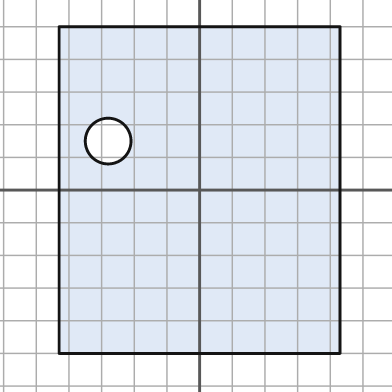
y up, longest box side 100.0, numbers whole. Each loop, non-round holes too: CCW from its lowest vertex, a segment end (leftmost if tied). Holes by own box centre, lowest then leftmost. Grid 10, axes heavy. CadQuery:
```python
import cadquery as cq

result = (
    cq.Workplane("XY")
    .moveTo(-43.0, -50.0)
    .lineTo(43.0, -50.0)
    .lineTo(43.0, 50.0)
    .lineTo(-43.0, 50.0)
    .close()
    .moveTo(-28.0, 15.0)
    .circle(7.0)
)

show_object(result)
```